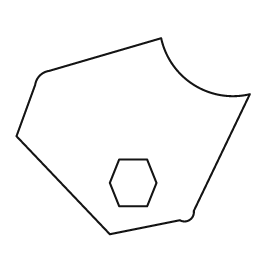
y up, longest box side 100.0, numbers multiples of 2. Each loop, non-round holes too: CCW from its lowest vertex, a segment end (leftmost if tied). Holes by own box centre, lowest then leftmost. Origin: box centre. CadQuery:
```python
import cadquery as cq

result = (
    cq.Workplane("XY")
    .moveTo(-10.0, -42.0)
    .lineTo(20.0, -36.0)
    .threePointArc((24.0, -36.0), (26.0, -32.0))
    .lineTo(50.0, 18.0)
    .threePointArc((26.0, 22.0), (12.0, 42.0))
    .lineTo(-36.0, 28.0)
    .threePointArc((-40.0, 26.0), (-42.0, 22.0))
    .lineTo(-50.0, 0.0)
    .close()
    .moveTo(-6.0, -30.0)
    .lineTo(6.0, -30.0)
    .lineTo(10.0, -20.0)
    .lineTo(6.0, -10.0)
    .lineTo(-6.0, -10.0)
    .lineTo(-10.0, -20.0)
    .close()
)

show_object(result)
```